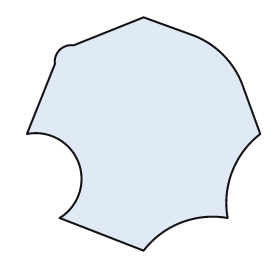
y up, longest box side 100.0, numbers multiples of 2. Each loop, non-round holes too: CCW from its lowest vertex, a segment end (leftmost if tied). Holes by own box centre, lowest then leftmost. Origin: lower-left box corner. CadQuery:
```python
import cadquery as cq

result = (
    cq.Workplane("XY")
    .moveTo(50.0, 0.0)
    .threePointArc((66.0, 12.0), (86.0, 14.0))
    .threePointArc((88.0, 34.0), (100.0, 50.0))
    .lineTo(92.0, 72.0)
    .threePointArc((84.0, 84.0), (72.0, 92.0))
    .lineTo(50.0, 100.0)
    .lineTo(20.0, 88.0)
    .threePointArc((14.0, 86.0), (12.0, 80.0))
    .lineTo(0.0, 50.0)
    .threePointArc((22.0, 38.0), (14.0, 14.0))
    .close()
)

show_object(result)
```